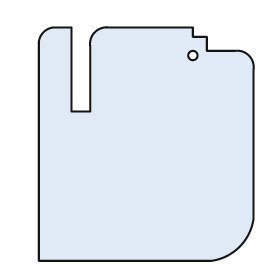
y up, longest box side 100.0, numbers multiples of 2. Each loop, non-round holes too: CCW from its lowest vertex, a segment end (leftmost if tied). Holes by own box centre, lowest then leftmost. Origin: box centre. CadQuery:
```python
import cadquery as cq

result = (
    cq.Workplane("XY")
    .moveTo(-46.0, -50.0)
    .lineTo(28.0, -50.0)
    .threePointArc((40.0, -44.0), (46.0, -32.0))
    .lineTo(46.0, 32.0)
    .threePointArc((44.0, 38.0), (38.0, 40.0))
    .lineTo(26.0, 40.0)
    .lineTo(26.0, 46.0)
    .lineTo(20.0, 46.0)
    .lineTo(20.0, 50.0)
    .lineTo(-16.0, 50.0)
    .threePointArc((-22.0, 48.0), (-24.0, 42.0))
    .lineTo(-24.0, 14.0)
    .lineTo(-32.0, 14.0)
    .lineTo(-32.0, 50.0)
    .lineTo(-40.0, 50.0)
    .threePointArc((-44.0, 48.0), (-46.0, 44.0))
    .close()
    .moveTo(20.0, 38.0)
    .circle(2.0)
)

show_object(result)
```